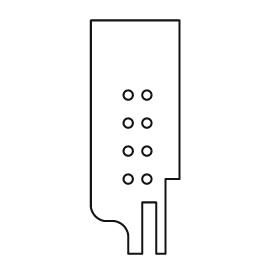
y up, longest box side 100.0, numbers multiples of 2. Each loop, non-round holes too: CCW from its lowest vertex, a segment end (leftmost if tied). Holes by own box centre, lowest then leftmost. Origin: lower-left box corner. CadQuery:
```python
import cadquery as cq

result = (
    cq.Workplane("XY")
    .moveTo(16.0, 0.0)
    .lineTo(22.0, 0.0)
    .lineTo(22.0, 22.0)
    .lineTo(28.0, 22.0)
    .lineTo(28.0, 0.0)
    .lineTo(32.0, 0.0)
    .lineTo(32.0, 32.0)
    .lineTo(38.0, 32.0)
    .lineTo(38.0, 100.0)
    .lineTo(0.0, 100.0)
    .lineTo(0.0, 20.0)
    .threePointArc((2.0, 16.0), (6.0, 14.0))
    .lineTo(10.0, 14.0)
    .threePointArc((14.0, 12.0), (16.0, 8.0))
    .close()
    .moveTo(16.0, 32.0)
    .circle(2.0)
    .moveTo(24.0, 32.0)
    .circle(2.0)
    .moveTo(16.0, 44.0)
    .circle(2.0)
    .moveTo(24.0, 44.0)
    .circle(2.0)
    .moveTo(16.0, 56.0)
    .circle(2.0)
    .moveTo(24.0, 56.0)
    .circle(2.0)
    .moveTo(16.0, 68.0)
    .circle(2.0)
    .moveTo(24.0, 68.0)
    .circle(2.0)
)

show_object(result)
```